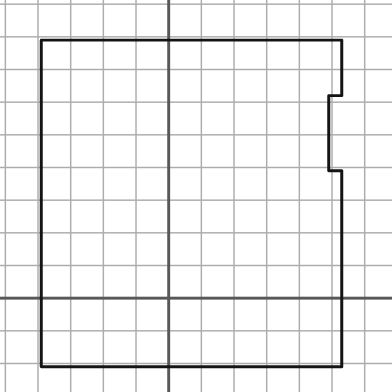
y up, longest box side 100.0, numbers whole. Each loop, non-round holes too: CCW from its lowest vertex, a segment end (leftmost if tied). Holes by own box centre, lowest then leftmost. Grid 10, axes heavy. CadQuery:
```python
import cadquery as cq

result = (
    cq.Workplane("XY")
    .moveTo(-39.0, -21.0)
    .lineTo(53.0, -21.0)
    .lineTo(53.0, 39.0)
    .lineTo(49.0, 39.0)
    .lineTo(49.0, 62.0)
    .lineTo(53.0, 62.0)
    .lineTo(53.0, 79.0)
    .lineTo(-39.0, 79.0)
    .close()
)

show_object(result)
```